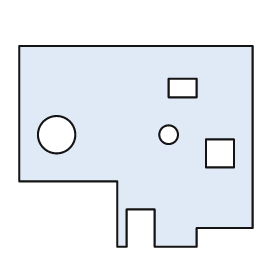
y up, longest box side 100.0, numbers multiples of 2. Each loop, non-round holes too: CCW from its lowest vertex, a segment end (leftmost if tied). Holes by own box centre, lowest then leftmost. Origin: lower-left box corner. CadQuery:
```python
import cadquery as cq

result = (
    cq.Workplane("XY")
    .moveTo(42.0, 0.0)
    .lineTo(46.0, 0.0)
    .lineTo(46.0, 16.0)
    .lineTo(58.0, 16.0)
    .lineTo(58.0, 0.0)
    .lineTo(76.0, 0.0)
    .lineTo(76.0, 8.0)
    .lineTo(100.0, 8.0)
    .lineTo(100.0, 86.0)
    .lineTo(0.0, 86.0)
    .lineTo(0.0, 28.0)
    .lineTo(42.0, 28.0)
    .close()
    .moveTo(80.0, 34.0)
    .lineTo(92.0, 34.0)
    .lineTo(92.0, 46.0)
    .lineTo(80.0, 46.0)
    .close()
    .moveTo(16.0, 48.0)
    .circle(8.0)
    .moveTo(64.0, 48.0)
    .circle(4.0)
    .moveTo(64.0, 64.0)
    .lineTo(76.0, 64.0)
    .lineTo(76.0, 72.0)
    .lineTo(64.0, 72.0)
    .close()
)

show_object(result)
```